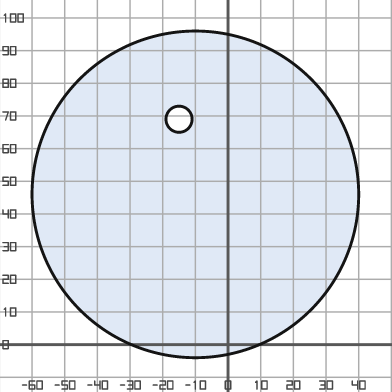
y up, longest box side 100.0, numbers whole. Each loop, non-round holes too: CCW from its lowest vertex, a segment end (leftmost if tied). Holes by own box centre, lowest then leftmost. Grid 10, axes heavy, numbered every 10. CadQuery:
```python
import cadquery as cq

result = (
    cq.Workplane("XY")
    .moveTo(-10.0, 46.0)
    .circle(50.0)
    .moveTo(-15.0, 69.0)
    .circle(4.0)
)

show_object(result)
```